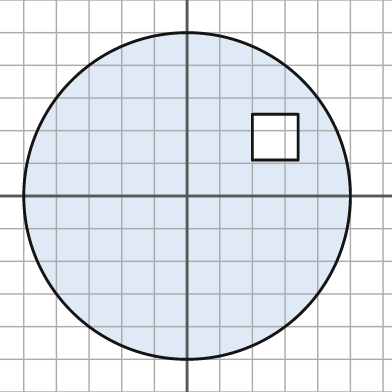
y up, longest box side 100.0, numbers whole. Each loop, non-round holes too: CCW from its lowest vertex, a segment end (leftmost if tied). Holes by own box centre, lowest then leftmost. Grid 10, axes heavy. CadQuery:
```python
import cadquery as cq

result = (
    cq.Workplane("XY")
    .moveTo(0.0, 0.0)
    .circle(50.0)
    .moveTo(20.0, 11.0)
    .lineTo(34.0, 11.0)
    .lineTo(34.0, 25.0)
    .lineTo(20.0, 25.0)
    .close()
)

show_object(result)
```